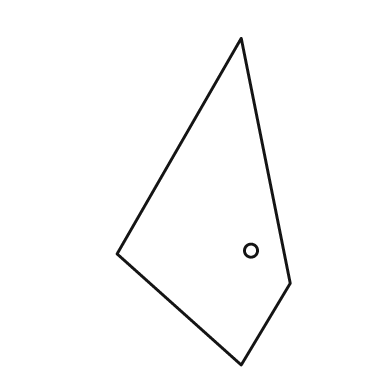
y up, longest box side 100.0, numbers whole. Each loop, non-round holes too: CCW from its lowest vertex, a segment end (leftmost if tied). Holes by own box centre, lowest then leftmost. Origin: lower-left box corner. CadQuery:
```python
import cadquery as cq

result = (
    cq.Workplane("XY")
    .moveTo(38.0, 0.0)
    .lineTo(53.0, 25.0)
    .lineTo(38.0, 100.0)
    .lineTo(0.0, 34.0)
    .close()
    .moveTo(41.0, 35.0)
    .circle(2.0)
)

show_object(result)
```